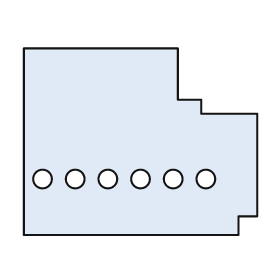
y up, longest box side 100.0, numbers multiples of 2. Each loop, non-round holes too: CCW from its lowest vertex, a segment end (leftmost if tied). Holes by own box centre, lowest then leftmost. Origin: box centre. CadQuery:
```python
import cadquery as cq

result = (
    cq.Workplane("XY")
    .moveTo(-50.0, -40.0)
    .lineTo(42.0, -40.0)
    .lineTo(42.0, -32.0)
    .lineTo(50.0, -32.0)
    .lineTo(50.0, 12.0)
    .lineTo(26.0, 12.0)
    .lineTo(26.0, 18.0)
    .lineTo(16.0, 18.0)
    .lineTo(16.0, 40.0)
    .lineTo(-50.0, 40.0)
    .close()
    .moveTo(-42.0, -16.0)
    .circle(4.0)
    .moveTo(-28.0, -16.0)
    .circle(4.0)
    .moveTo(-14.0, -16.0)
    .circle(4.0)
    .moveTo(0.0, -16.0)
    .circle(4.0)
    .moveTo(14.0, -16.0)
    .circle(4.0)
    .moveTo(28.0, -16.0)
    .circle(4.0)
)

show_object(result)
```